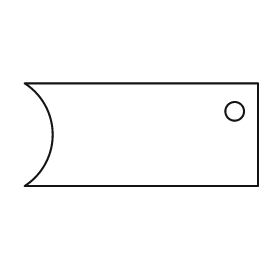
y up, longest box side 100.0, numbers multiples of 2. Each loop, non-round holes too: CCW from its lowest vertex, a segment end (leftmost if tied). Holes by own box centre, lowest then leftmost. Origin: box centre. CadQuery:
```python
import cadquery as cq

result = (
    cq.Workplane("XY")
    .moveTo(-50.0, -22.0)
    .lineTo(50.0, -22.0)
    .lineTo(50.0, 22.0)
    .lineTo(-50.0, 22.0)
    .threePointArc((-38.0, 0.0), (-50.0, -22.0))
    .close()
    .moveTo(40.0, 10.0)
    .circle(4.0)
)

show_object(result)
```